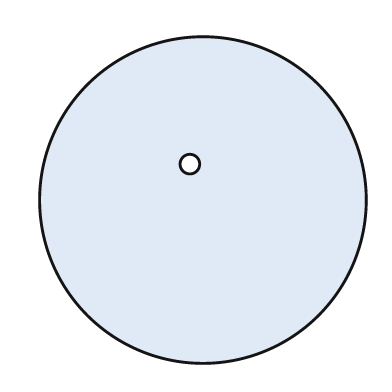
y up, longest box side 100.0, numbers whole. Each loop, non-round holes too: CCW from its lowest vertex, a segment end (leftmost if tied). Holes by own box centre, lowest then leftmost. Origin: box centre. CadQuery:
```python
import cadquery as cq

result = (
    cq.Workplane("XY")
    .moveTo(0.0, 0.0)
    .circle(50.0)
    .moveTo(-4.0, 11.0)
    .circle(3.0)
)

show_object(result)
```